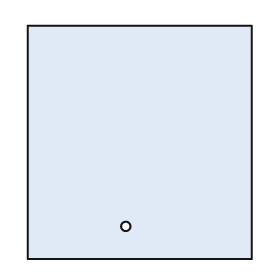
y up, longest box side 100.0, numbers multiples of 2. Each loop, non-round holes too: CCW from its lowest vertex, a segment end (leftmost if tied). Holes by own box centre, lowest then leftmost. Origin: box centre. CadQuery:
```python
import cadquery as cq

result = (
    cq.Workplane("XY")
    .moveTo(-48.0, -50.0)
    .lineTo(48.0, -50.0)
    .lineTo(48.0, 50.0)
    .lineTo(-48.0, 50.0)
    .close()
    .moveTo(-6.0, -36.0)
    .circle(2.0)
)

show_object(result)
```